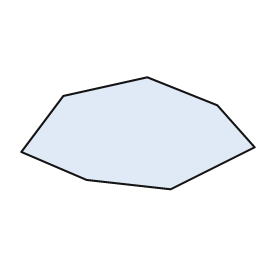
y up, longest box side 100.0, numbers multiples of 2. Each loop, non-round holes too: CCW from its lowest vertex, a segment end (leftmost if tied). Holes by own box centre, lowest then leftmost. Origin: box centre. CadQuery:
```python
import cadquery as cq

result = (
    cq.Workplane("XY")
    .moveTo(14.0, -24.0)
    .lineTo(50.0, -6.0)
    .lineTo(34.0, 12.0)
    .lineTo(4.0, 24.0)
    .lineTo(-32.0, 16.0)
    .lineTo(-50.0, -8.0)
    .lineTo(-22.0, -20.0)
    .close()
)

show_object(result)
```